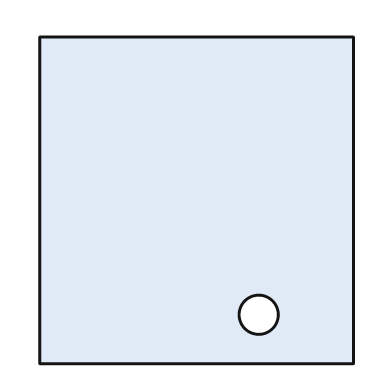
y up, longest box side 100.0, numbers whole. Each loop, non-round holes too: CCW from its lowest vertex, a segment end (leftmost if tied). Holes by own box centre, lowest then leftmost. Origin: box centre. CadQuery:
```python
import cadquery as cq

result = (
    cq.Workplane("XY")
    .moveTo(-48.0, -50.0)
    .lineTo(48.0, -50.0)
    .lineTo(48.0, 50.0)
    .lineTo(-48.0, 50.0)
    .close()
    .moveTo(19.0, -35.0)
    .circle(6.0)
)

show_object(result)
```